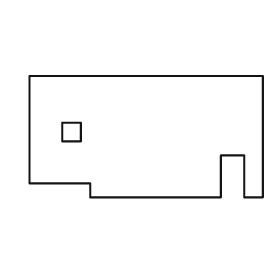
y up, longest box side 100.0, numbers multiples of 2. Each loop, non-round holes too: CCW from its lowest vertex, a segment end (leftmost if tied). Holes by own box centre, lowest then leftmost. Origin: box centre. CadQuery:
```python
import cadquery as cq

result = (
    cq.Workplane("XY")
    .moveTo(-24.0, -26.0)
    .lineTo(32.0, -26.0)
    .lineTo(32.0, -8.0)
    .lineTo(42.0, -8.0)
    .lineTo(42.0, -26.0)
    .lineTo(50.0, -26.0)
    .lineTo(50.0, 26.0)
    .lineTo(-50.0, 26.0)
    .lineTo(-50.0, -20.0)
    .lineTo(-24.0, -20.0)
    .close()
    .moveTo(-36.0, -2.0)
    .lineTo(-28.0, -2.0)
    .lineTo(-28.0, 6.0)
    .lineTo(-36.0, 6.0)
    .close()
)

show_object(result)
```